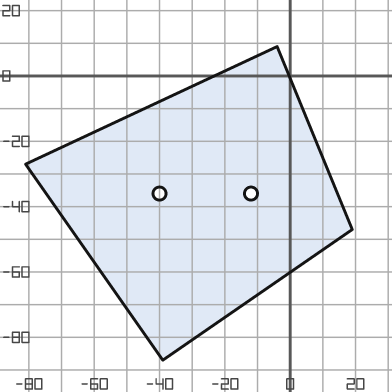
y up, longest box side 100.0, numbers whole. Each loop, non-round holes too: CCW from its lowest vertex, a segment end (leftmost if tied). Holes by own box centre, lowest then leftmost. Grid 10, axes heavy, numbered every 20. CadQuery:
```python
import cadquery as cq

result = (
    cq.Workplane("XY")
    .moveTo(-39.0, -87.0)
    .lineTo(19.0, -47.0)
    .lineTo(-4.0, 9.0)
    .lineTo(-81.0, -27.0)
    .close()
    .moveTo(-40.0, -36.0)
    .circle(2.0)
    .moveTo(-12.0, -36.0)
    .circle(2.0)
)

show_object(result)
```